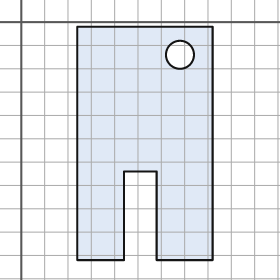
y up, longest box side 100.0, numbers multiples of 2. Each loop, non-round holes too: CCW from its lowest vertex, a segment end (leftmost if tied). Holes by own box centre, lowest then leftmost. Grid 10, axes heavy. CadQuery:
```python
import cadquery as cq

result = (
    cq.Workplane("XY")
    .moveTo(24.0, -102.0)
    .lineTo(44.0, -102.0)
    .lineTo(44.0, -64.0)
    .lineTo(58.0, -64.0)
    .lineTo(58.0, -102.0)
    .lineTo(82.0, -102.0)
    .lineTo(82.0, -2.0)
    .lineTo(24.0, -2.0)
    .close()
    .moveTo(68.0, -14.0)
    .circle(6.0)
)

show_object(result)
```